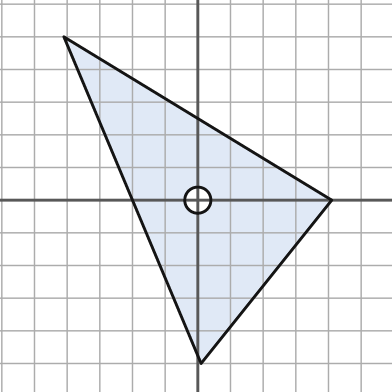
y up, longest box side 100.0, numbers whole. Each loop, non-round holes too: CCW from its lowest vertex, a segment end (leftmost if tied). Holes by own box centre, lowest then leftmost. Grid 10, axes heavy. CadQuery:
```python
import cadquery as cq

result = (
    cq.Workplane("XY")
    .moveTo(1.0, -50.0)
    .lineTo(41.0, 0.0)
    .lineTo(-41.0, 50.0)
    .close()
    .moveTo(0.0, 0.0)
    .circle(4.0)
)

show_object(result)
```